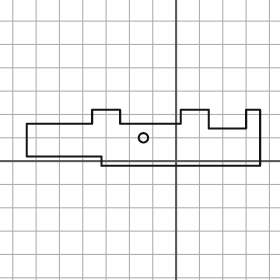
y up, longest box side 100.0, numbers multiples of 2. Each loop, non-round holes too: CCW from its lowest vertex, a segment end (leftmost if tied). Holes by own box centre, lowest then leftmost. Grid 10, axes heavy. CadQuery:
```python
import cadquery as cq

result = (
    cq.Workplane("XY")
    .moveTo(-32.0, -2.0)
    .lineTo(36.0, -2.0)
    .lineTo(36.0, 22.0)
    .lineTo(30.0, 22.0)
    .lineTo(30.0, 14.0)
    .lineTo(14.0, 14.0)
    .lineTo(14.0, 22.0)
    .lineTo(2.0, 22.0)
    .lineTo(2.0, 16.0)
    .lineTo(-24.0, 16.0)
    .lineTo(-24.0, 22.0)
    .lineTo(-36.0, 22.0)
    .lineTo(-36.0, 16.0)
    .lineTo(-64.0, 16.0)
    .lineTo(-64.0, 2.0)
    .lineTo(-32.0, 2.0)
    .close()
    .moveTo(-14.0, 10.0)
    .circle(2.0)
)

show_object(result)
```